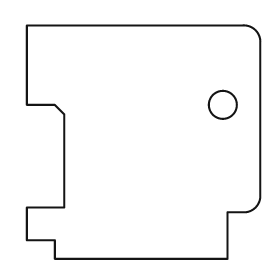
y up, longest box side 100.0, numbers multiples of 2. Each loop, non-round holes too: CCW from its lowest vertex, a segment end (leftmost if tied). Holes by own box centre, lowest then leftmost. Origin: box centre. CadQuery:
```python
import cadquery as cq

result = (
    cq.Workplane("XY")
    .moveTo(-38.0, -50.0)
    .lineTo(36.0, -50.0)
    .lineTo(36.0, -30.0)
    .lineTo(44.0, -30.0)
    .threePointArc((48.0, -28.0), (50.0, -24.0))
    .lineTo(50.0, 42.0)
    .threePointArc((48.0, 48.0), (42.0, 50.0))
    .lineTo(-50.0, 50.0)
    .lineTo(-50.0, 16.0)
    .lineTo(-38.0, 16.0)
    .lineTo(-34.0, 12.0)
    .lineTo(-34.0, -28.0)
    .lineTo(-50.0, -28.0)
    .lineTo(-50.0, -42.0)
    .lineTo(-38.0, -42.0)
    .close()
    .moveTo(34.0, 16.0)
    .circle(6.0)
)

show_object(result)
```